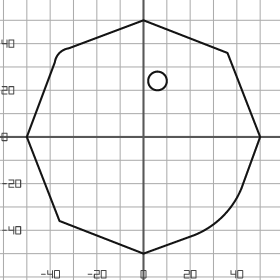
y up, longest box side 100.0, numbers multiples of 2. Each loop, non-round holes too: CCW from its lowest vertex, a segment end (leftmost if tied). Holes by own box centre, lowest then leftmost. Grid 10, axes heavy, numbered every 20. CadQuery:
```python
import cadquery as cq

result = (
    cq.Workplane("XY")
    .moveTo(0.0, -50.0)
    .lineTo(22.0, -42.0)
    .threePointArc((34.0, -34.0), (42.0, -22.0))
    .lineTo(50.0, 0.0)
    .lineTo(36.0, 36.0)
    .lineTo(0.0, 50.0)
    .lineTo(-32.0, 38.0)
    .threePointArc((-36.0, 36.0), (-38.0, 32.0))
    .lineTo(-50.0, 0.0)
    .lineTo(-36.0, -36.0)
    .close()
    .moveTo(6.0, 24.0)
    .circle(4.0)
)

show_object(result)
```